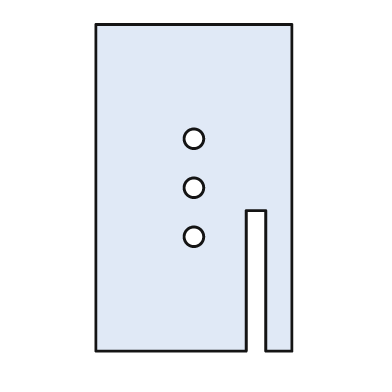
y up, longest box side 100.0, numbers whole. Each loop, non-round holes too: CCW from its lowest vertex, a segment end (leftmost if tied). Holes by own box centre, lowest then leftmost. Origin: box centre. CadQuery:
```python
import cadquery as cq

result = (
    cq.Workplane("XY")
    .moveTo(-30.0, -50.0)
    .lineTo(16.0, -50.0)
    .lineTo(16.0, -7.0)
    .lineTo(22.0, -7.0)
    .lineTo(22.0, -50.0)
    .lineTo(30.0, -50.0)
    .lineTo(30.0, 50.0)
    .lineTo(-30.0, 50.0)
    .close()
    .moveTo(0.0, -15.0)
    .circle(3.0)
    .moveTo(0.0, 0.0)
    .circle(3.0)
    .moveTo(0.0, 15.0)
    .circle(3.0)
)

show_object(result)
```